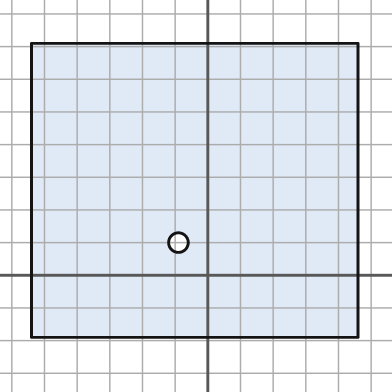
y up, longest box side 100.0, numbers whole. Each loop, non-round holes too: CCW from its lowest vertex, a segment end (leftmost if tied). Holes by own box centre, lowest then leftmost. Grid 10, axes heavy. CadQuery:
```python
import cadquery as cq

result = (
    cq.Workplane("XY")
    .moveTo(-54.0, -19.0)
    .lineTo(46.0, -19.0)
    .lineTo(46.0, 71.0)
    .lineTo(-54.0, 71.0)
    .close()
    .moveTo(-9.0, 10.0)
    .circle(3.0)
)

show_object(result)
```